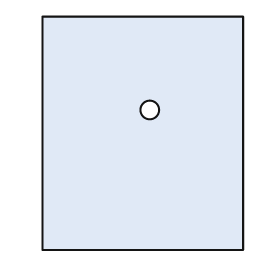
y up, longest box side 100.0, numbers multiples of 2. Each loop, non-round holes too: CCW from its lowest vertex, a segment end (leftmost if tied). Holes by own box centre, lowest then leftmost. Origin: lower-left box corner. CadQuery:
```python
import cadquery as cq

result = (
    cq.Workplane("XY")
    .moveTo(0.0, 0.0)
    .lineTo(86.0, 0.0)
    .lineTo(86.0, 100.0)
    .lineTo(0.0, 100.0)
    .close()
    .moveTo(46.0, 60.0)
    .circle(4.0)
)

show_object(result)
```